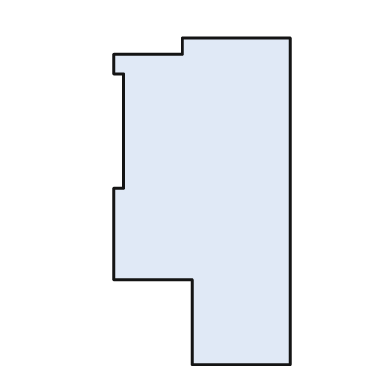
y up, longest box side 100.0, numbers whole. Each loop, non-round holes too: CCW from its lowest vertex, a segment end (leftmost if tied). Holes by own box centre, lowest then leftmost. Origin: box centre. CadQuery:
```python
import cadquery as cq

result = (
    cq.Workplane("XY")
    .moveTo(-3.0, -50.0)
    .lineTo(27.0, -50.0)
    .lineTo(27.0, 50.0)
    .lineTo(-6.0, 50.0)
    .lineTo(-6.0, 45.0)
    .lineTo(-27.0, 45.0)
    .lineTo(-27.0, 39.0)
    .lineTo(-24.0, 39.0)
    .lineTo(-24.0, 4.0)
    .lineTo(-27.0, 4.0)
    .lineTo(-27.0, -24.0)
    .lineTo(-3.0, -24.0)
    .close()
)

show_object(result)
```